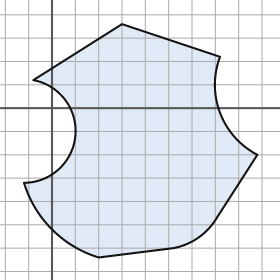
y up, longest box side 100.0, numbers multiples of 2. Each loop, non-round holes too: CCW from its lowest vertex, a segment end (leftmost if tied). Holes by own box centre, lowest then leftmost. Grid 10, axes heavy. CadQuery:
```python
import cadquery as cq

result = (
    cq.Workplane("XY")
    .moveTo(20.0, -64.0)
    .lineTo(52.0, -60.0)
    .threePointArc((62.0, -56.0), (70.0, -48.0))
    .lineTo(88.0, -20.0)
    .threePointArc((72.0, -2.0), (72.0, 22.0))
    .lineTo(30.0, 36.0)
    .lineTo(-8.0, 12.0)
    .threePointArc((10.0, -12.0), (-12.0, -32.0))
    .threePointArc((0.0, -52.0), (20.0, -64.0))
    .close()
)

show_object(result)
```